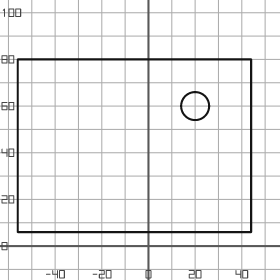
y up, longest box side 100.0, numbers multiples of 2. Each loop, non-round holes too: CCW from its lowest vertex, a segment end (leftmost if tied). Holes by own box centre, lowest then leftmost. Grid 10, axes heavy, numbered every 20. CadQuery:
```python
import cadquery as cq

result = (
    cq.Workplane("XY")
    .moveTo(-56.0, 6.0)
    .lineTo(44.0, 6.0)
    .lineTo(44.0, 80.0)
    .lineTo(-56.0, 80.0)
    .close()
    .moveTo(20.0, 60.0)
    .circle(6.0)
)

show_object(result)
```